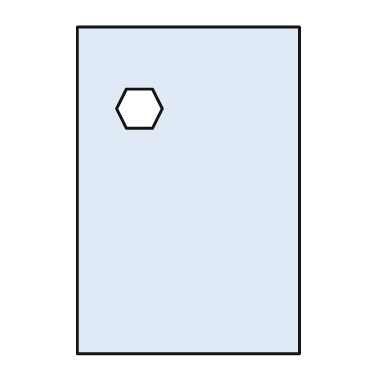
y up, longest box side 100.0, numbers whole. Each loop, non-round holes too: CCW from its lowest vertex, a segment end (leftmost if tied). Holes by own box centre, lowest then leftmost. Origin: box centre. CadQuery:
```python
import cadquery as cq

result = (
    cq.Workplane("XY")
    .moveTo(-34.0, -50.0)
    .lineTo(34.0, -50.0)
    .lineTo(34.0, 50.0)
    .lineTo(-34.0, 50.0)
    .close()
    .moveTo(-19.0, 19.0)
    .lineTo(-11.0, 19.0)
    .lineTo(-8.0, 25.0)
    .lineTo(-11.0, 31.0)
    .lineTo(-19.0, 31.0)
    .lineTo(-22.0, 25.0)
    .close()
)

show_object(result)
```